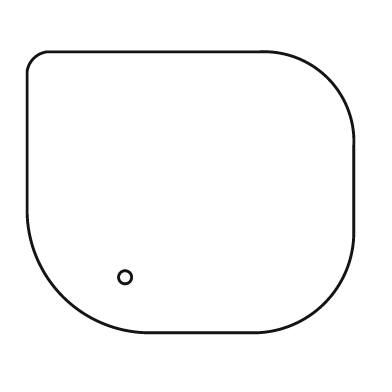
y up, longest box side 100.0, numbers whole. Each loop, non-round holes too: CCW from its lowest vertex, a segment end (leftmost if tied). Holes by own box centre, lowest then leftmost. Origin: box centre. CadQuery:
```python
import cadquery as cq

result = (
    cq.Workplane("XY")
    .moveTo(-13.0, -43.0)
    .lineTo(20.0, -43.0)
    .threePointArc((41.0, -34.0), (50.0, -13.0))
    .lineTo(50.0, 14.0)
    .threePointArc((42.0, 35.0), (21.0, 43.0))
    .lineTo(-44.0, 43.0)
    .threePointArc((-48.0, 41.0), (-50.0, 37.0))
    .lineTo(-50.0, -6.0)
    .threePointArc((-39.0, -32.0), (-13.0, -43.0))
    .close()
    .moveTo(-20.0, -26.0)
    .circle(2.0)
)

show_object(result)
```